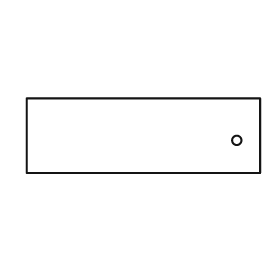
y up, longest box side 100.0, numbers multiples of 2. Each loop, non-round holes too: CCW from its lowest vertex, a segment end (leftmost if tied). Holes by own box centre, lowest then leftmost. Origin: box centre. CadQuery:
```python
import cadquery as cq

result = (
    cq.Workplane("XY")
    .moveTo(-50.0, -16.0)
    .lineTo(50.0, -16.0)
    .lineTo(50.0, 16.0)
    .lineTo(-50.0, 16.0)
    .close()
    .moveTo(40.0, -2.0)
    .circle(2.0)
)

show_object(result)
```